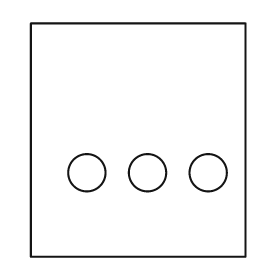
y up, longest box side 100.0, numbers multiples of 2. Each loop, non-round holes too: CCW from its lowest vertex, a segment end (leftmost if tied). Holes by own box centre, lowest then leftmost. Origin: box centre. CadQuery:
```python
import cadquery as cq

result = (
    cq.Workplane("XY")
    .moveTo(-46.0, -50.0)
    .lineTo(46.0, -50.0)
    .lineTo(46.0, 50.0)
    .lineTo(-46.0, 50.0)
    .close()
    .moveTo(-22.0, -14.0)
    .circle(8.0)
    .moveTo(4.0, -14.0)
    .circle(8.0)
    .moveTo(30.0, -14.0)
    .circle(8.0)
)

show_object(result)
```